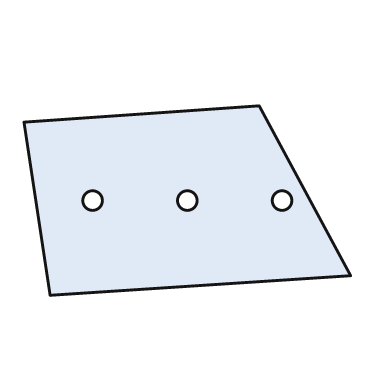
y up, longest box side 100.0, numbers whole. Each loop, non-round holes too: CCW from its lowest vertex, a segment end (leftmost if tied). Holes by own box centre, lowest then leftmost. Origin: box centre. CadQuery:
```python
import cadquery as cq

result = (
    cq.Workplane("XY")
    .moveTo(-42.0, -29.0)
    .lineTo(50.0, -23.0)
    .lineTo(22.0, 29.0)
    .lineTo(-50.0, 24.0)
    .close()
    .moveTo(-29.0, 0.0)
    .circle(3.0)
    .moveTo(0.0, 0.0)
    .circle(3.0)
    .moveTo(29.0, 0.0)
    .circle(3.0)
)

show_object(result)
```